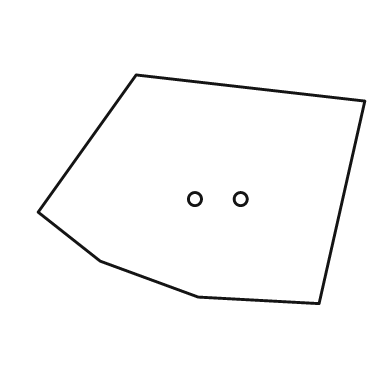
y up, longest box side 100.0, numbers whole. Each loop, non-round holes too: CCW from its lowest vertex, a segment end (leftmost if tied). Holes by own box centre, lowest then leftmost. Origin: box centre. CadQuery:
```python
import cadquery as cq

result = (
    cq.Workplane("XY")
    .moveTo(36.0, -35.0)
    .lineTo(50.0, 27.0)
    .lineTo(-20.0, 35.0)
    .lineTo(-50.0, -7.0)
    .lineTo(-31.0, -22.0)
    .lineTo(-1.0, -33.0)
    .close()
    .moveTo(-2.0, -3.0)
    .circle(2.0)
    .moveTo(12.0, -3.0)
    .circle(2.0)
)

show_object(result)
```